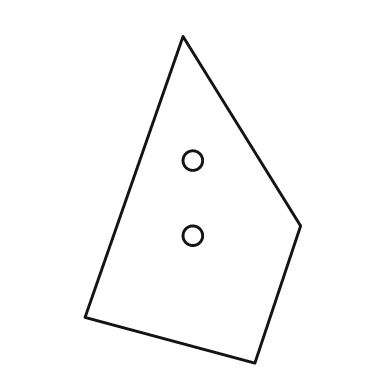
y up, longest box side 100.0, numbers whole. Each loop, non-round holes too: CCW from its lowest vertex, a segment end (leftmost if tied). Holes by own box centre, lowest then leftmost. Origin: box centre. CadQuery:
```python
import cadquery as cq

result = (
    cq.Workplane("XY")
    .moveTo(19.0, -50.0)
    .lineTo(33.0, -8.0)
    .lineTo(-3.0, 50.0)
    .lineTo(-33.0, -36.0)
    .close()
    .moveTo(0.0, -11.0)
    .circle(3.0)
    .moveTo(0.0, 12.0)
    .circle(3.0)
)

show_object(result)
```